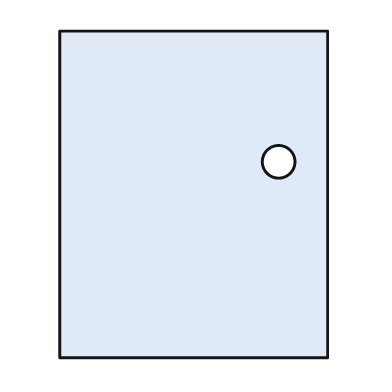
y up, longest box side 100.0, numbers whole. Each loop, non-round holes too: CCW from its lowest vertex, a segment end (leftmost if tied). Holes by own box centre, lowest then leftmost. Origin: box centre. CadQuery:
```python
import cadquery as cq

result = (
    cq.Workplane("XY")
    .moveTo(-41.0, -50.0)
    .lineTo(41.0, -50.0)
    .lineTo(41.0, 50.0)
    .lineTo(-41.0, 50.0)
    .close()
    .moveTo(26.0, 10.0)
    .circle(5.0)
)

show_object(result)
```